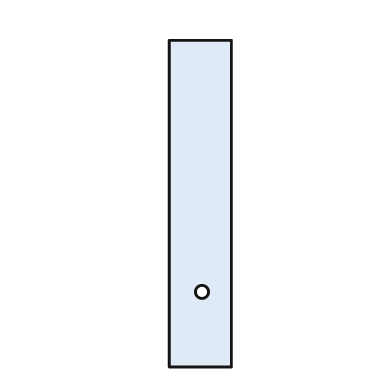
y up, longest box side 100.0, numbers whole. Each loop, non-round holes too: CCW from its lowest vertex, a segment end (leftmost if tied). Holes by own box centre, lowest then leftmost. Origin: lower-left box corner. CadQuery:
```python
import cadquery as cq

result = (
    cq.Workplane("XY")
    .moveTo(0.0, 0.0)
    .lineTo(19.0, 0.0)
    .lineTo(19.0, 100.0)
    .lineTo(0.0, 100.0)
    .close()
    .moveTo(10.0, 23.0)
    .circle(2.0)
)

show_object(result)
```